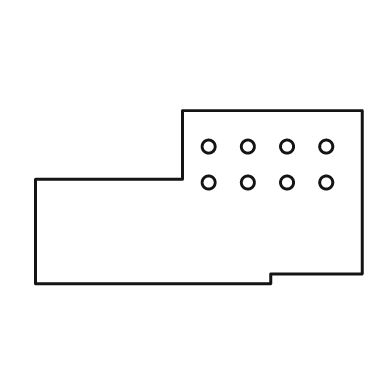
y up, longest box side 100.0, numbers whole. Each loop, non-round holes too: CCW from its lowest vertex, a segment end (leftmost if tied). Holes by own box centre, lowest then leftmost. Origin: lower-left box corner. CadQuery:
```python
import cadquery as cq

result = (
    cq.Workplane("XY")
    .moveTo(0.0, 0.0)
    .lineTo(72.0, 0.0)
    .lineTo(72.0, 3.0)
    .lineTo(100.0, 3.0)
    .lineTo(100.0, 53.0)
    .lineTo(45.0, 53.0)
    .lineTo(45.0, 32.0)
    .lineTo(0.0, 32.0)
    .close()
    .moveTo(53.0, 31.0)
    .circle(2.0)
    .moveTo(65.0, 31.0)
    .circle(2.0)
    .moveTo(77.0, 31.0)
    .circle(2.0)
    .moveTo(89.0, 31.0)
    .circle(2.0)
    .moveTo(53.0, 42.0)
    .circle(2.0)
    .moveTo(65.0, 42.0)
    .circle(2.0)
    .moveTo(77.0, 42.0)
    .circle(2.0)
    .moveTo(89.0, 42.0)
    .circle(2.0)
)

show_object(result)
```